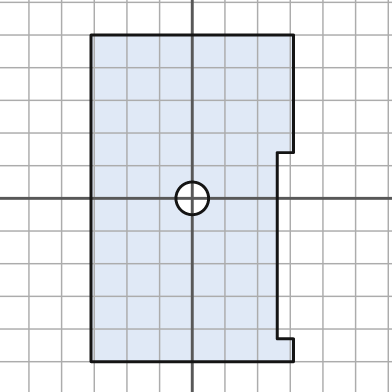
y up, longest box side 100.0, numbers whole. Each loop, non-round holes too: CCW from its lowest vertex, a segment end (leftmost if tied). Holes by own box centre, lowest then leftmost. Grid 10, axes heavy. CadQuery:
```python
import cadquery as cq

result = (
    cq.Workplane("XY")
    .moveTo(-31.0, -50.0)
    .lineTo(31.0, -50.0)
    .lineTo(31.0, -43.0)
    .lineTo(26.0, -43.0)
    .lineTo(26.0, 14.0)
    .lineTo(31.0, 14.0)
    .lineTo(31.0, 50.0)
    .lineTo(-31.0, 50.0)
    .close()
    .moveTo(0.0, 0.0)
    .circle(5.0)
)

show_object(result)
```